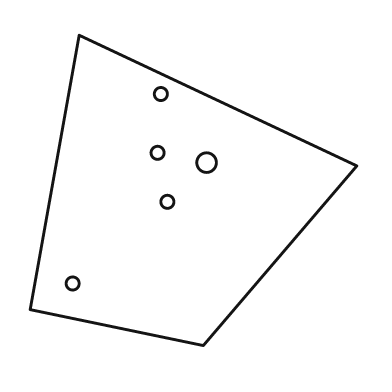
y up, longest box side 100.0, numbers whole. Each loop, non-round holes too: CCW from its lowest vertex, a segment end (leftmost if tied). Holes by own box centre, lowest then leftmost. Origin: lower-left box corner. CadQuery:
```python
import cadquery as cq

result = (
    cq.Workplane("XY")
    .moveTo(53.0, 0.0)
    .lineTo(100.0, 55.0)
    .lineTo(15.0, 95.0)
    .lineTo(0.0, 11.0)
    .close()
    .moveTo(13.0, 19.0)
    .circle(2.0)
    .moveTo(42.0, 44.0)
    .circle(2.0)
    .moveTo(54.0, 56.0)
    .circle(3.0)
    .moveTo(39.0, 59.0)
    .circle(2.0)
    .moveTo(40.0, 77.0)
    .circle(2.0)
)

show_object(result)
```